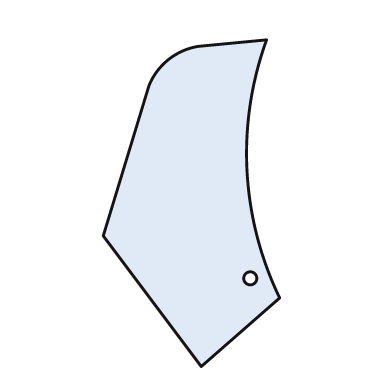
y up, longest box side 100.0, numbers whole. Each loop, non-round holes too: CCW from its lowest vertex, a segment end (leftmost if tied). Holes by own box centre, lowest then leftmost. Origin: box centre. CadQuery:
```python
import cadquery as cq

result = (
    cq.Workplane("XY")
    .moveTo(3.0, -50.0)
    .lineTo(27.0, -29.0)
    .threePointArc((17.0, 10.0), (23.0, 50.0))
    .lineTo(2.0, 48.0)
    .threePointArc((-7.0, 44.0), (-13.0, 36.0))
    .lineTo(-27.0, -10.0)
    .close()
    .moveTo(18.0, -23.0)
    .circle(2.0)
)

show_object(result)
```